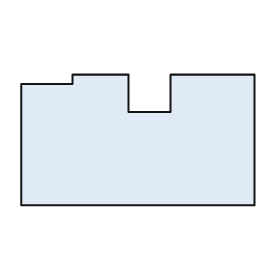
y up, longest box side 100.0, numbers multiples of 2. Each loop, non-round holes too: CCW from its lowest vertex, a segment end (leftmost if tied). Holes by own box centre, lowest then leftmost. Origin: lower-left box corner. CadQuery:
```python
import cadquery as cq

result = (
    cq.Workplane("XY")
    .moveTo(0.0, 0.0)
    .lineTo(100.0, 0.0)
    .lineTo(100.0, 56.0)
    .lineTo(64.0, 56.0)
    .lineTo(64.0, 40.0)
    .lineTo(46.0, 40.0)
    .lineTo(46.0, 56.0)
    .lineTo(22.0, 56.0)
    .lineTo(22.0, 52.0)
    .lineTo(0.0, 52.0)
    .close()
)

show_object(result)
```